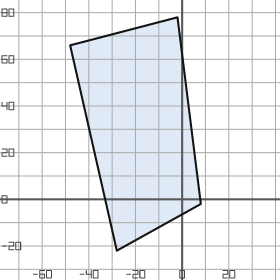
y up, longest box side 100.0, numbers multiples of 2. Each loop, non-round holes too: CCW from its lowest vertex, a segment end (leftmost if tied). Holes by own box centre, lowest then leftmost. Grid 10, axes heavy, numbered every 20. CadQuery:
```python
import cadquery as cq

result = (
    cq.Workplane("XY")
    .moveTo(-28.0, -22.0)
    .lineTo(8.0, -2.0)
    .lineTo(-2.0, 78.0)
    .lineTo(-48.0, 66.0)
    .close()
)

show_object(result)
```